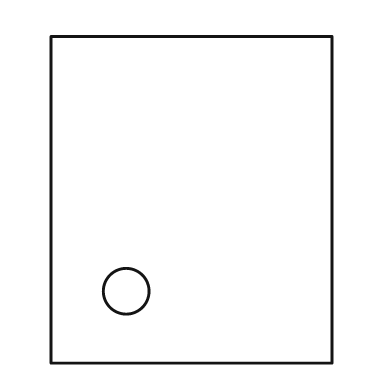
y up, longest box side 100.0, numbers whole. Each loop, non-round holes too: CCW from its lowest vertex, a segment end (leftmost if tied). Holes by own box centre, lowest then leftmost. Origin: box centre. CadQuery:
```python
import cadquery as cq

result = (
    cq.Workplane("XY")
    .moveTo(-43.0, -50.0)
    .lineTo(43.0, -50.0)
    .lineTo(43.0, 50.0)
    .lineTo(-43.0, 50.0)
    .close()
    .moveTo(-20.0, -28.0)
    .circle(7.0)
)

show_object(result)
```